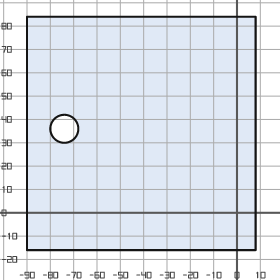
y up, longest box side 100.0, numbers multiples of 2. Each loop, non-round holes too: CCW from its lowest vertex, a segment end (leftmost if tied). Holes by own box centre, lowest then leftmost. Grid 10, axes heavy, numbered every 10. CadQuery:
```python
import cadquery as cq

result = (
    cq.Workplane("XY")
    .moveTo(-90.0, -16.0)
    .lineTo(8.0, -16.0)
    .lineTo(8.0, 84.0)
    .lineTo(-90.0, 84.0)
    .close()
    .moveTo(-74.0, 36.0)
    .circle(6.0)
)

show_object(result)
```